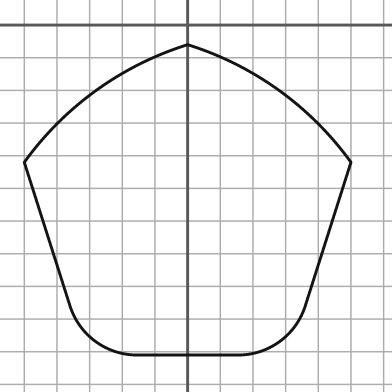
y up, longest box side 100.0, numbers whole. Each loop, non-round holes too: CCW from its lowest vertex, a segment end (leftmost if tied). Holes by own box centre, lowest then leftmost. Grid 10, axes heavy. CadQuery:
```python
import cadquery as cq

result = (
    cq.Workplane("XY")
    .moveTo(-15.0, -101.0)
    .lineTo(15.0, -101.0)
    .threePointArc((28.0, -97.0), (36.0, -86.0))
    .lineTo(50.0, -42.0)
    .threePointArc((28.0, -20.0), (0.0, -6.0))
    .threePointArc((-28.0, -20.0), (-50.0, -42.0))
    .lineTo(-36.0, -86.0)
    .threePointArc((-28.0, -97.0), (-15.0, -101.0))
    .close()
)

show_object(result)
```